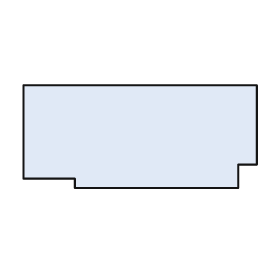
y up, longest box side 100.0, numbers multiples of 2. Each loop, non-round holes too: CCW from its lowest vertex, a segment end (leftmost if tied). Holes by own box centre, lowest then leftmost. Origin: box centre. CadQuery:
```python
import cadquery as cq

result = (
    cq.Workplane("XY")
    .moveTo(-28.0, -22.0)
    .lineTo(42.0, -22.0)
    .lineTo(42.0, -12.0)
    .lineTo(50.0, -12.0)
    .lineTo(50.0, 22.0)
    .lineTo(-50.0, 22.0)
    .lineTo(-50.0, -18.0)
    .lineTo(-28.0, -18.0)
    .close()
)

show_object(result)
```